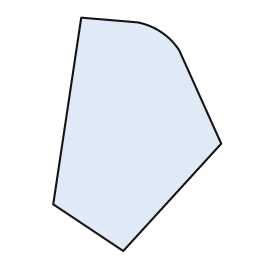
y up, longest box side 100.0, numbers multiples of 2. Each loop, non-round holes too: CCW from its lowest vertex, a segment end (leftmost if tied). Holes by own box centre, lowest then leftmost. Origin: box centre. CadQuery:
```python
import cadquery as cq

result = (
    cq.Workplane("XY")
    .moveTo(-6.0, -50.0)
    .lineTo(36.0, -4.0)
    .lineTo(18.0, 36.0)
    .threePointArc((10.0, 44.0), (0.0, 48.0))
    .lineTo(-24.0, 50.0)
    .lineTo(-36.0, -30.0)
    .close()
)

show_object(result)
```